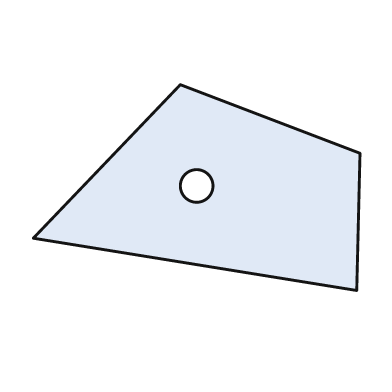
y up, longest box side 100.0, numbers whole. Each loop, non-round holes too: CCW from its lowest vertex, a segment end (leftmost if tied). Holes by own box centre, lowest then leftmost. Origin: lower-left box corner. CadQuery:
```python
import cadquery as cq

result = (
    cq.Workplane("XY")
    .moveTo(99.0, 0.0)
    .lineTo(100.0, 42.0)
    .lineTo(45.0, 63.0)
    .lineTo(0.0, 16.0)
    .close()
    .moveTo(50.0, 32.0)
    .circle(5.0)
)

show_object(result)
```